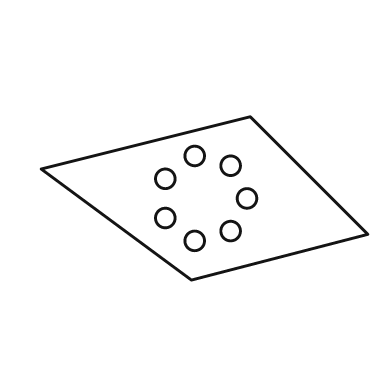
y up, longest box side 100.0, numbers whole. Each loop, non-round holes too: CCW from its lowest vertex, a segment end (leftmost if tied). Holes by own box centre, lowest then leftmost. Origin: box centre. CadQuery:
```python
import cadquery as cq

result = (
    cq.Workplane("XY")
    .moveTo(-4.0, -25.0)
    .lineTo(50.0, -11.0)
    .lineTo(14.0, 25.0)
    .lineTo(-50.0, 9.0)
    .close()
    .moveTo(-3.0, -13.0)
    .circle(3.0)
    .moveTo(8.0, -10.0)
    .circle(3.0)
    .moveTo(-12.0, -6.0)
    .circle(3.0)
    .moveTo(13.0, 0.0)
    .circle(3.0)
    .moveTo(-12.0, 6.0)
    .circle(3.0)
    .moveTo(8.0, 10.0)
    .circle(3.0)
    .moveTo(-3.0, 13.0)
    .circle(3.0)
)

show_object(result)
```